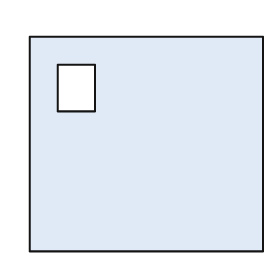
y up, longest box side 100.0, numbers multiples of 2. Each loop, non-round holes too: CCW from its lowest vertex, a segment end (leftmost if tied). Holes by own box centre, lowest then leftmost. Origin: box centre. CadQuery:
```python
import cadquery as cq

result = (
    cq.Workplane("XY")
    .moveTo(-50.0, -46.0)
    .lineTo(50.0, -46.0)
    .lineTo(50.0, 46.0)
    .lineTo(-50.0, 46.0)
    .close()
    .moveTo(-38.0, 14.0)
    .lineTo(-22.0, 14.0)
    .lineTo(-22.0, 34.0)
    .lineTo(-38.0, 34.0)
    .close()
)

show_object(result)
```